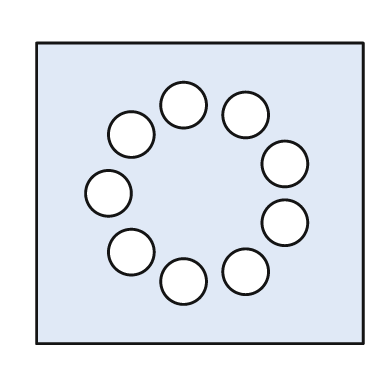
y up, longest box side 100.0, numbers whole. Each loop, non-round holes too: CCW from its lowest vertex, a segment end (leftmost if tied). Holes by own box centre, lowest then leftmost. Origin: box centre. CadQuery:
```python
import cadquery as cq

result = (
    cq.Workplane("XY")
    .moveTo(-50.0, -46.0)
    .lineTo(50.0, -46.0)
    .lineTo(50.0, 46.0)
    .lineTo(-50.0, 46.0)
    .close()
    .moveTo(-5.0, -27.0)
    .circle(7.0)
    .moveTo(14.0, -24.0)
    .circle(7.0)
    .moveTo(-21.0, -18.0)
    .circle(7.0)
    .moveTo(26.0, -9.0)
    .circle(7.0)
    .moveTo(-28.0, 0.0)
    .circle(7.0)
    .moveTo(26.0, 9.0)
    .circle(7.0)
    .moveTo(-21.0, 18.0)
    .circle(7.0)
    .moveTo(14.0, 24.0)
    .circle(7.0)
    .moveTo(-5.0, 27.0)
    .circle(7.0)
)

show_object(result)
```